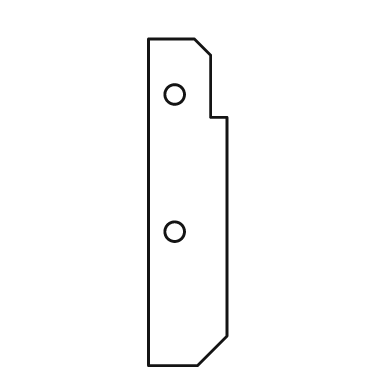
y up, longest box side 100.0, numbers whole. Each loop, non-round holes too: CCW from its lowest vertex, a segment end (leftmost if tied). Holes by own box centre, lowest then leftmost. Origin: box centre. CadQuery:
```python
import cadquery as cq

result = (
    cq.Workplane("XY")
    .moveTo(-12.0, -50.0)
    .lineTo(3.0, -50.0)
    .lineTo(12.0, -41.0)
    .lineTo(12.0, 26.0)
    .lineTo(7.0, 26.0)
    .lineTo(7.0, 45.0)
    .lineTo(2.0, 50.0)
    .lineTo(-12.0, 50.0)
    .close()
    .moveTo(-4.0, -9.0)
    .circle(3.0)
    .moveTo(-4.0, 33.0)
    .circle(3.0)
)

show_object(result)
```